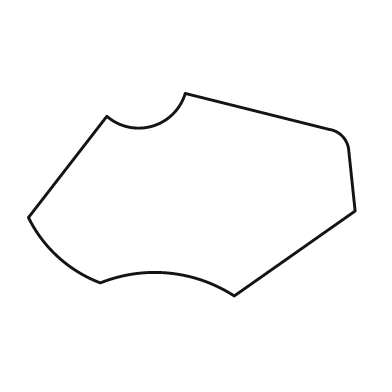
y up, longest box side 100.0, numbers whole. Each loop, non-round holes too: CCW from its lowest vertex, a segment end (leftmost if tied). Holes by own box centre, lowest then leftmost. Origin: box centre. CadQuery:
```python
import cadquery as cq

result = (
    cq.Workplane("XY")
    .moveTo(13.0, -31.0)
    .lineTo(50.0, -5.0)
    .lineTo(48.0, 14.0)
    .threePointArc((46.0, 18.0), (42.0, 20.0))
    .lineTo(-2.0, 31.0)
    .threePointArc((-12.0, 21.0), (-26.0, 24.0))
    .lineTo(-50.0, -7.0)
    .threePointArc((-41.0, -19.0), (-28.0, -27.0))
    .threePointArc((-7.0, -24.0), (13.0, -31.0))
    .close()
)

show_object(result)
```